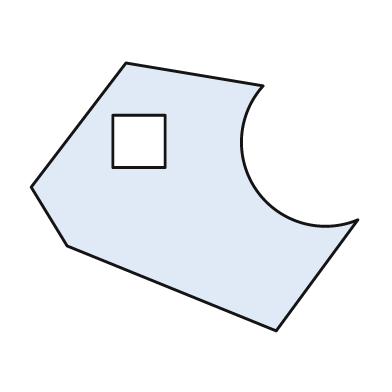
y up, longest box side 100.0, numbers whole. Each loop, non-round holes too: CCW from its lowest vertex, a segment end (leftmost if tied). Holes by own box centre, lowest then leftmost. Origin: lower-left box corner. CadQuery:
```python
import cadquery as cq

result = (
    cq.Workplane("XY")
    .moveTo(75.0, 0.0)
    .lineTo(100.0, 34.0)
    .threePointArc((69.0, 43.0), (71.0, 75.0))
    .lineTo(29.0, 82.0)
    .lineTo(0.0, 44.0)
    .lineTo(11.0, 26.0)
    .close()
    .moveTo(25.0, 50.0)
    .lineTo(41.0, 50.0)
    .lineTo(41.0, 66.0)
    .lineTo(25.0, 66.0)
    .close()
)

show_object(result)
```